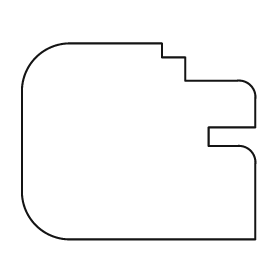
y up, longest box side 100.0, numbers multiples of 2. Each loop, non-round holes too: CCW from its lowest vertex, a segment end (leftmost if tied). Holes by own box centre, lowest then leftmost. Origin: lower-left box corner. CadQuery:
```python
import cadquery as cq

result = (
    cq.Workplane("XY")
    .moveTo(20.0, 0.0)
    .lineTo(100.0, 0.0)
    .lineTo(100.0, 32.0)
    .threePointArc((98.0, 38.0), (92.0, 40.0))
    .lineTo(80.0, 40.0)
    .lineTo(80.0, 48.0)
    .lineTo(100.0, 48.0)
    .lineTo(100.0, 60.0)
    .threePointArc((98.0, 66.0), (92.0, 68.0))
    .lineTo(70.0, 68.0)
    .lineTo(70.0, 78.0)
    .lineTo(60.0, 78.0)
    .lineTo(60.0, 84.0)
    .lineTo(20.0, 84.0)
    .threePointArc((6.0, 78.0), (0.0, 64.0))
    .lineTo(0.0, 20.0)
    .threePointArc((6.0, 6.0), (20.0, 0.0))
    .close()
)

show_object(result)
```